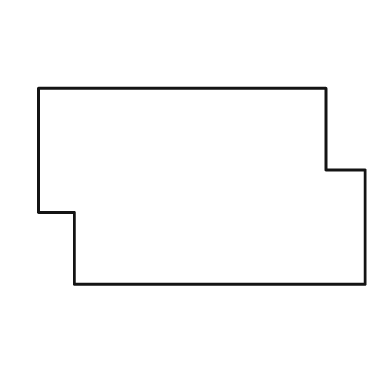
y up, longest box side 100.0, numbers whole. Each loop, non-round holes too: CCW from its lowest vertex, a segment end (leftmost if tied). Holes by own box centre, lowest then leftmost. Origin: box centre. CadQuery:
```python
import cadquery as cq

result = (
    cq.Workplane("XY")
    .moveTo(-39.0, -30.0)
    .lineTo(50.0, -30.0)
    .lineTo(50.0, 5.0)
    .lineTo(38.0, 5.0)
    .lineTo(38.0, 30.0)
    .lineTo(-50.0, 30.0)
    .lineTo(-50.0, -8.0)
    .lineTo(-39.0, -8.0)
    .close()
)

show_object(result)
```